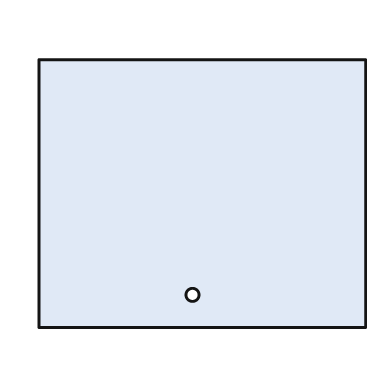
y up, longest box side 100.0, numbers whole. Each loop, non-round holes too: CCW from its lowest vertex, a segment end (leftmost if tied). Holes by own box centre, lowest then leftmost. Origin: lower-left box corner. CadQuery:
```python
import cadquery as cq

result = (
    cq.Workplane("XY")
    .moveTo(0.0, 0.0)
    .lineTo(100.0, 0.0)
    .lineTo(100.0, 82.0)
    .lineTo(0.0, 82.0)
    .close()
    .moveTo(47.0, 10.0)
    .circle(2.0)
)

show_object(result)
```